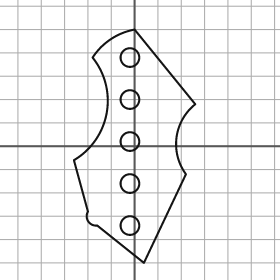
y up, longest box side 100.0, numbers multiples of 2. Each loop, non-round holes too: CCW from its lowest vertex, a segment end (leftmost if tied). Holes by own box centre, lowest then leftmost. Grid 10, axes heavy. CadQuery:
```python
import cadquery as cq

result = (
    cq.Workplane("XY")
    .moveTo(4.0, -50.0)
    .lineTo(22.0, -12.0)
    .threePointArc((18.0, 4.0), (26.0, 18.0))
    .lineTo(0.0, 50.0)
    .threePointArc((-10.0, 46.0), (-18.0, 38.0))
    .threePointArc((-12.0, 14.0), (-26.0, -6.0))
    .lineTo(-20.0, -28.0)
    .threePointArc((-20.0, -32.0), (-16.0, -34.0))
    .close()
    .moveTo(-2.0, -34.0)
    .circle(4.0)
    .moveTo(-2.0, -16.0)
    .circle(4.0)
    .moveTo(-2.0, 2.0)
    .circle(4.0)
    .moveTo(-2.0, 20.0)
    .circle(4.0)
    .moveTo(-2.0, 38.0)
    .circle(4.0)
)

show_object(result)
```